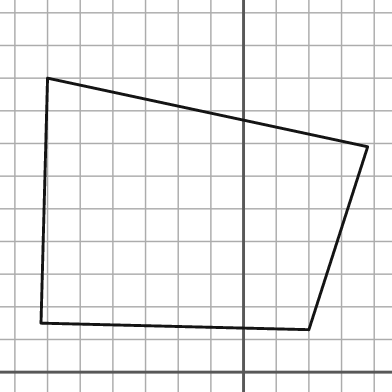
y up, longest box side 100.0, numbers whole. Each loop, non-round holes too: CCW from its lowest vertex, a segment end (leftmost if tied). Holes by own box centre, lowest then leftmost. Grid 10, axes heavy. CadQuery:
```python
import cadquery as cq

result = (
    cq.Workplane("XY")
    .moveTo(20.0, 13.0)
    .lineTo(38.0, 69.0)
    .lineTo(-60.0, 90.0)
    .lineTo(-62.0, 15.0)
    .close()
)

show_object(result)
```